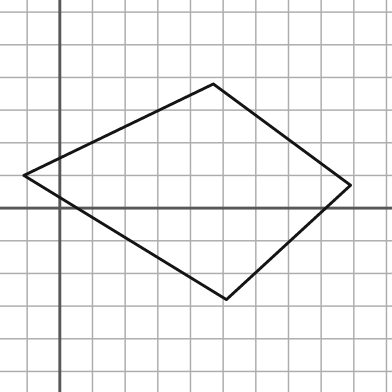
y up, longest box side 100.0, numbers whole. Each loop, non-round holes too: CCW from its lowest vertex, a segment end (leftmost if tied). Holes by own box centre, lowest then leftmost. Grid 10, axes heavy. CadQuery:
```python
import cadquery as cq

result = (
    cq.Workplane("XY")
    .moveTo(51.0, -28.0)
    .lineTo(89.0, 7.0)
    .lineTo(47.0, 38.0)
    .lineTo(-11.0, 10.0)
    .close()
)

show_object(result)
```